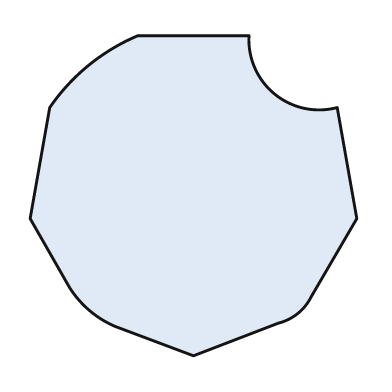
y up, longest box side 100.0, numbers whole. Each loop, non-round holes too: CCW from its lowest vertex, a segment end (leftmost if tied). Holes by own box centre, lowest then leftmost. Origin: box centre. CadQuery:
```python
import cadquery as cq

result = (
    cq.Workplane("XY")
    .moveTo(0.0, -49.0)
    .lineTo(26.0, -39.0)
    .threePointArc((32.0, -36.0), (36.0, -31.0))
    .lineTo(50.0, -7.0)
    .lineTo(44.0, 27.0)
    .threePointArc((25.0, 31.0), (17.0, 49.0))
    .lineTo(-17.0, 49.0)
    .threePointArc((-32.0, 40.0), (-44.0, 27.0))
    .lineTo(-50.0, -7.0)
    .lineTo(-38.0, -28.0)
    .threePointArc((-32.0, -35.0), (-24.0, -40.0))
    .close()
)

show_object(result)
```